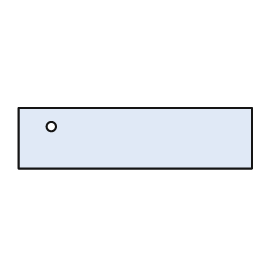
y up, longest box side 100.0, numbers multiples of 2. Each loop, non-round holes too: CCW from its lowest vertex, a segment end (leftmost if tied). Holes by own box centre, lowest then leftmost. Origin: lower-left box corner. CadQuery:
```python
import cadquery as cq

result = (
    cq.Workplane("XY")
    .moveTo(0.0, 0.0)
    .lineTo(100.0, 0.0)
    .lineTo(100.0, 26.0)
    .lineTo(0.0, 26.0)
    .close()
    .moveTo(14.0, 18.0)
    .circle(2.0)
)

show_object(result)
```